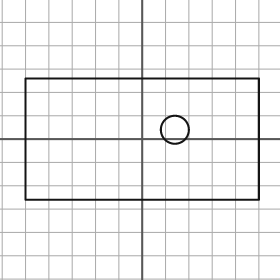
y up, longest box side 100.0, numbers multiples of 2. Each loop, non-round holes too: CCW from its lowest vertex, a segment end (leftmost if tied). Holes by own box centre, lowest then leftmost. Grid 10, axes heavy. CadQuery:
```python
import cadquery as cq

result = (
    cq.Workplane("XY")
    .moveTo(-50.0, -26.0)
    .lineTo(50.0, -26.0)
    .lineTo(50.0, 26.0)
    .lineTo(-50.0, 26.0)
    .close()
    .moveTo(14.0, 4.0)
    .circle(6.0)
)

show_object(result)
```